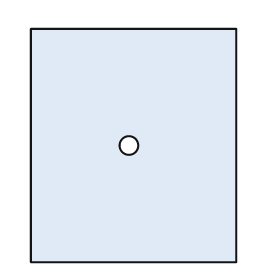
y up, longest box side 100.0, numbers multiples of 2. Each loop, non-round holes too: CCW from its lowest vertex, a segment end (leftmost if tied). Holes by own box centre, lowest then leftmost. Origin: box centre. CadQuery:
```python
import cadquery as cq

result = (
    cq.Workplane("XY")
    .moveTo(-44.0, -50.0)
    .lineTo(44.0, -50.0)
    .lineTo(44.0, 50.0)
    .lineTo(-44.0, 50.0)
    .close()
    .moveTo(-2.0, 0.0)
    .circle(4.0)
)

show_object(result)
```